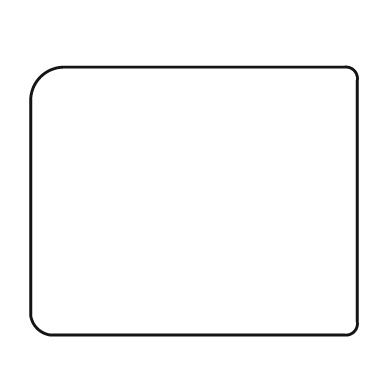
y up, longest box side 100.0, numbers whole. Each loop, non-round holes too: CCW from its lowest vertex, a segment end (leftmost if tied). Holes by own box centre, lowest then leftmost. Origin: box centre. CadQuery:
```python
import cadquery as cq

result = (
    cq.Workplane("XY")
    .moveTo(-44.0, -41.0)
    .lineTo(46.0, -41.0)
    .threePointArc((49.0, -40.0), (50.0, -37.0))
    .lineTo(50.0, 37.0)
    .threePointArc((49.0, 40.0), (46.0, 41.0))
    .lineTo(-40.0, 41.0)
    .threePointArc((-47.0, 38.0), (-50.0, 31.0))
    .lineTo(-50.0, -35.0)
    .threePointArc((-48.0, -39.0), (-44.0, -41.0))
    .close()
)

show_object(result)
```